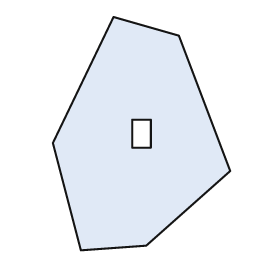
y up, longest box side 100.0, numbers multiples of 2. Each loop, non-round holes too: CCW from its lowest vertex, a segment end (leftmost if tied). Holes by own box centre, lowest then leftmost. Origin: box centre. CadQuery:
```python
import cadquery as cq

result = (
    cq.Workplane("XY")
    .moveTo(-26.0, -50.0)
    .lineTo(2.0, -48.0)
    .lineTo(38.0, -16.0)
    .lineTo(16.0, 42.0)
    .lineTo(-12.0, 50.0)
    .lineTo(-38.0, -4.0)
    .close()
    .moveTo(-4.0, -6.0)
    .lineTo(4.0, -6.0)
    .lineTo(4.0, 6.0)
    .lineTo(-4.0, 6.0)
    .close()
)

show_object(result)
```